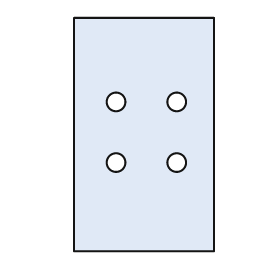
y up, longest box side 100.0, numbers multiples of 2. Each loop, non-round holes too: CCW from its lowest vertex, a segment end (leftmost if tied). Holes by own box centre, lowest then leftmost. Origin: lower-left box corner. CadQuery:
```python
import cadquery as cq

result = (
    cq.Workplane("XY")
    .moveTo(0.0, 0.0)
    .lineTo(60.0, 0.0)
    .lineTo(60.0, 100.0)
    .lineTo(0.0, 100.0)
    .close()
    .moveTo(18.0, 38.0)
    .circle(4.0)
    .moveTo(44.0, 38.0)
    .circle(4.0)
    .moveTo(18.0, 64.0)
    .circle(4.0)
    .moveTo(44.0, 64.0)
    .circle(4.0)
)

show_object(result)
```